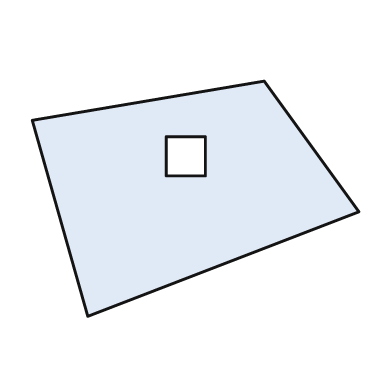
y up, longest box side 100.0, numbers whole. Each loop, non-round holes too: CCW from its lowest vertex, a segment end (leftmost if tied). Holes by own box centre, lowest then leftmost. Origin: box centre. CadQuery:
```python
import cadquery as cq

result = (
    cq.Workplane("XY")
    .moveTo(-33.0, -36.0)
    .lineTo(50.0, -4.0)
    .lineTo(21.0, 36.0)
    .lineTo(-50.0, 24.0)
    .close()
    .moveTo(-9.0, 7.0)
    .lineTo(3.0, 7.0)
    .lineTo(3.0, 19.0)
    .lineTo(-9.0, 19.0)
    .close()
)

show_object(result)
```